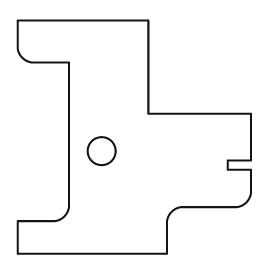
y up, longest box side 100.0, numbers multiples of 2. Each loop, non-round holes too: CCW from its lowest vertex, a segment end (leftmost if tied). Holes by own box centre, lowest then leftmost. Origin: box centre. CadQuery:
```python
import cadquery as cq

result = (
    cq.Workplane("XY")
    .moveTo(-50.0, -50.0)
    .lineTo(14.0, -50.0)
    .lineTo(14.0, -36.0)
    .threePointArc((16.0, -32.0), (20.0, -30.0))
    .lineTo(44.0, -30.0)
    .threePointArc((48.0, -28.0), (50.0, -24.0))
    .lineTo(50.0, -14.0)
    .lineTo(40.0, -14.0)
    .lineTo(40.0, -10.0)
    .lineTo(50.0, -10.0)
    .lineTo(50.0, 10.0)
    .lineTo(6.0, 10.0)
    .lineTo(6.0, 50.0)
    .lineTo(-50.0, 50.0)
    .lineTo(-50.0, 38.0)
    .threePointArc((-48.0, 34.0), (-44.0, 32.0))
    .lineTo(-28.0, 32.0)
    .lineTo(-28.0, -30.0)
    .threePointArc((-30.0, -34.0), (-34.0, -36.0))
    .lineTo(-50.0, -36.0)
    .close()
    .moveTo(-14.0, -6.0)
    .circle(6.0)
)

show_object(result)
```